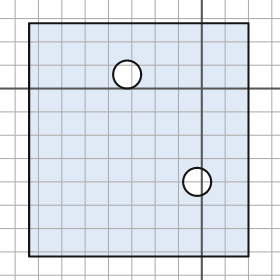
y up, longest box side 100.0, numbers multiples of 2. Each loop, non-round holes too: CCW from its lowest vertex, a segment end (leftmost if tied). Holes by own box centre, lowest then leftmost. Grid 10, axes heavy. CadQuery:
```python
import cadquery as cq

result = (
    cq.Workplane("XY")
    .moveTo(-74.0, -72.0)
    .lineTo(20.0, -72.0)
    .lineTo(20.0, 28.0)
    .lineTo(-74.0, 28.0)
    .close()
    .moveTo(-2.0, -40.0)
    .circle(6.0)
    .moveTo(-32.0, 6.0)
    .circle(6.0)
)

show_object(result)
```